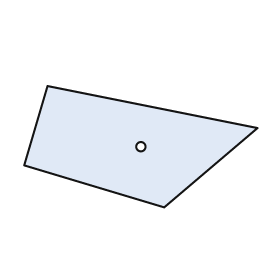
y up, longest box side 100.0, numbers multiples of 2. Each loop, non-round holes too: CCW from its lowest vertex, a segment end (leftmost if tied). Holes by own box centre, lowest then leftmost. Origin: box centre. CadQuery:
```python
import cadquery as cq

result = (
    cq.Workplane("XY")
    .moveTo(10.0, -26.0)
    .lineTo(50.0, 8.0)
    .lineTo(-40.0, 26.0)
    .lineTo(-50.0, -8.0)
    .close()
    .moveTo(0.0, 0.0)
    .circle(2.0)
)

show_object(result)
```